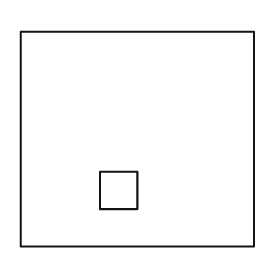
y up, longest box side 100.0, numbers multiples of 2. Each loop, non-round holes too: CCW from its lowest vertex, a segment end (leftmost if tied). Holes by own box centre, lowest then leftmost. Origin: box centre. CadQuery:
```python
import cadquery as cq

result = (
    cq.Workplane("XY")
    .moveTo(-50.0, -46.0)
    .lineTo(50.0, -46.0)
    .lineTo(50.0, 46.0)
    .lineTo(-50.0, 46.0)
    .close()
    .moveTo(-16.0, -30.0)
    .lineTo(0.0, -30.0)
    .lineTo(0.0, -14.0)
    .lineTo(-16.0, -14.0)
    .close()
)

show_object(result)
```